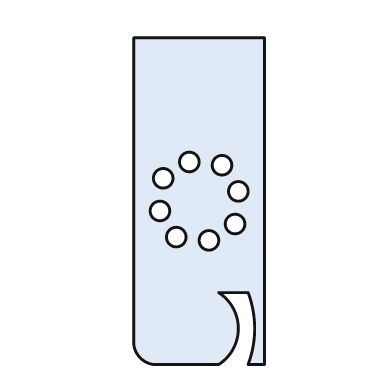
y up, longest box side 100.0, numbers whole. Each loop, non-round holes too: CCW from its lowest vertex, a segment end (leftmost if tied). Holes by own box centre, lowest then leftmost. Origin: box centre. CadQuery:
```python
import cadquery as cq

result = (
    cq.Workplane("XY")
    .moveTo(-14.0, -50.0)
    .lineTo(6.0, -50.0)
    .threePointArc((12.0, -39.0), (6.0, -28.0))
    .lineTo(15.0, -28.0)
    .threePointArc((17.0, -39.0), (15.0, -50.0))
    .lineTo(20.0, -50.0)
    .lineTo(20.0, 50.0)
    .lineTo(-20.0, 50.0)
    .lineTo(-20.0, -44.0)
    .threePointArc((-18.0, -48.0), (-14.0, -50.0))
    .close()
    .moveTo(3.0, -12.0)
    .circle(3.0)
    .moveTo(-7.0, -11.0)
    .circle(3.0)
    .moveTo(11.0, -7.0)
    .circle(3.0)
    .moveTo(-12.0, -3.0)
    .circle(3.0)
    .moveTo(12.0, 3.0)
    .circle(3.0)
    .moveTo(-11.0, 7.0)
    .circle(3.0)
    .moveTo(7.0, 11.0)
    .circle(3.0)
    .moveTo(-3.0, 12.0)
    .circle(3.0)
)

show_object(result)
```